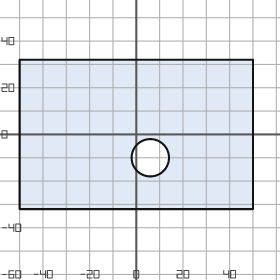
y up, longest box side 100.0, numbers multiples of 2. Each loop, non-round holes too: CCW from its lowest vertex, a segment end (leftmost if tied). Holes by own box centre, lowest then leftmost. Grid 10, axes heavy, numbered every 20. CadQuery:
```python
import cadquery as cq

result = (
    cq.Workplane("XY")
    .moveTo(-50.0, -32.0)
    .lineTo(50.0, -32.0)
    .lineTo(50.0, 32.0)
    .lineTo(-50.0, 32.0)
    .close()
    .moveTo(6.0, -10.0)
    .circle(8.0)
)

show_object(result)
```